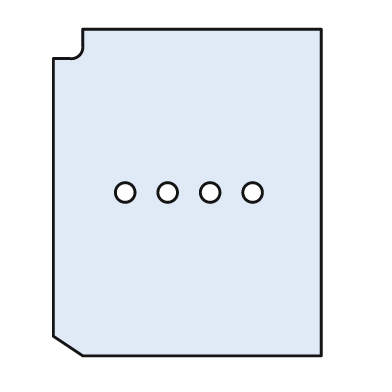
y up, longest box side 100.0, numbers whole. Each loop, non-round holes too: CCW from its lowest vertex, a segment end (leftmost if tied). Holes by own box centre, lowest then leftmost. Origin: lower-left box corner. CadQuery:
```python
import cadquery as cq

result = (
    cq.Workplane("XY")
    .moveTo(9.0, 0.0)
    .lineTo(82.0, 0.0)
    .lineTo(82.0, 100.0)
    .lineTo(9.0, 100.0)
    .lineTo(9.0, 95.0)
    .threePointArc((8.0, 92.0), (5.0, 91.0))
    .lineTo(0.0, 91.0)
    .lineTo(0.0, 6.0)
    .close()
    .moveTo(22.0, 50.0)
    .circle(3.0)
    .moveTo(35.0, 50.0)
    .circle(3.0)
    .moveTo(48.0, 50.0)
    .circle(3.0)
    .moveTo(61.0, 50.0)
    .circle(3.0)
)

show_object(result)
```